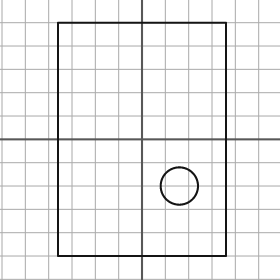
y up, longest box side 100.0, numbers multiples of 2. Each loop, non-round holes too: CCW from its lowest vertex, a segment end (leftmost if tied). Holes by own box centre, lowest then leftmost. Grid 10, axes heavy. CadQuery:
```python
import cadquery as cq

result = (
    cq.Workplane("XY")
    .moveTo(-36.0, -50.0)
    .lineTo(36.0, -50.0)
    .lineTo(36.0, 50.0)
    .lineTo(-36.0, 50.0)
    .close()
    .moveTo(16.0, -20.0)
    .circle(8.0)
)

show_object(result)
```